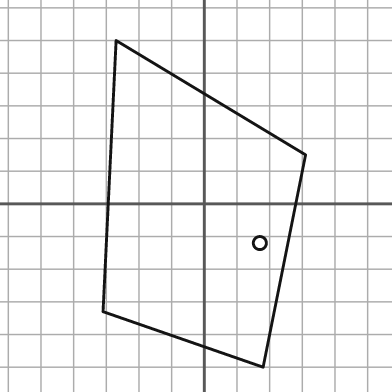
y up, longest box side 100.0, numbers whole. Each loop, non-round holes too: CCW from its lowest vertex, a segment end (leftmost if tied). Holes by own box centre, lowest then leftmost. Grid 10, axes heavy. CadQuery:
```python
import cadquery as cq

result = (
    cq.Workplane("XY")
    .moveTo(18.0, -50.0)
    .lineTo(31.0, 15.0)
    .lineTo(-27.0, 50.0)
    .lineTo(-31.0, -33.0)
    .close()
    .moveTo(17.0, -12.0)
    .circle(2.0)
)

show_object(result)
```